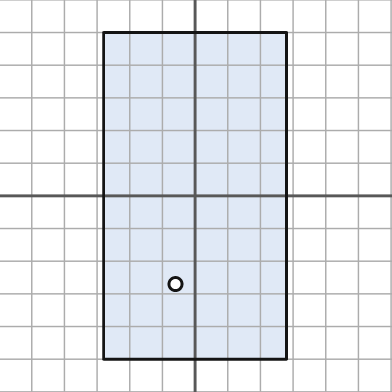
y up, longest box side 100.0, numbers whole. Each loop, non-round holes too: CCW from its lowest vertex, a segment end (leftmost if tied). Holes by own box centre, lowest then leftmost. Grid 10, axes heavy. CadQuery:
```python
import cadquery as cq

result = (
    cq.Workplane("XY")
    .moveTo(-28.0, -50.0)
    .lineTo(28.0, -50.0)
    .lineTo(28.0, 50.0)
    .lineTo(-28.0, 50.0)
    .close()
    .moveTo(-6.0, -27.0)
    .circle(2.0)
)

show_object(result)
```